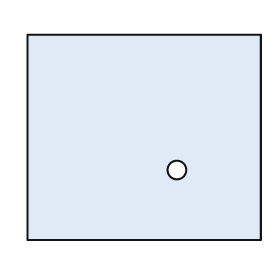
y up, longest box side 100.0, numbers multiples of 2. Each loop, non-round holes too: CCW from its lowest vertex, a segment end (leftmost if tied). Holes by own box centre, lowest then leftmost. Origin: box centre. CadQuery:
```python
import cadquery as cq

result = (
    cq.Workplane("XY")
    .moveTo(-50.0, -44.0)
    .lineTo(50.0, -44.0)
    .lineTo(50.0, 44.0)
    .lineTo(-50.0, 44.0)
    .close()
    .moveTo(14.0, -14.0)
    .circle(4.0)
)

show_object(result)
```